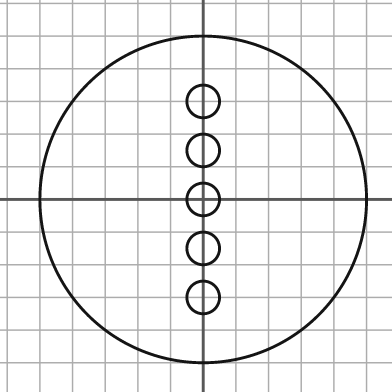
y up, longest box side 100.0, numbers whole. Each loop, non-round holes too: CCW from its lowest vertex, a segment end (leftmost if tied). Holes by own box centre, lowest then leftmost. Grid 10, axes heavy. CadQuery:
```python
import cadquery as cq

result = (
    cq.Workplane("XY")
    .moveTo(0.0, 0.0)
    .circle(50.0)
    .moveTo(0.0, -30.0)
    .circle(5.0)
    .moveTo(0.0, -15.0)
    .circle(5.0)
    .moveTo(0.0, 0.0)
    .circle(5.0)
    .moveTo(0.0, 15.0)
    .circle(5.0)
    .moveTo(0.0, 30.0)
    .circle(5.0)
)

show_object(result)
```